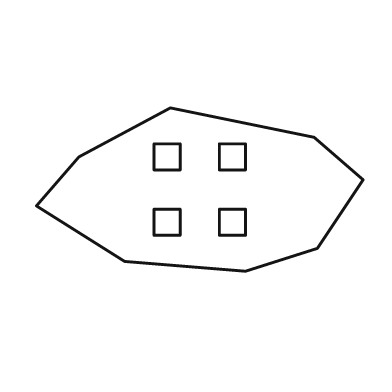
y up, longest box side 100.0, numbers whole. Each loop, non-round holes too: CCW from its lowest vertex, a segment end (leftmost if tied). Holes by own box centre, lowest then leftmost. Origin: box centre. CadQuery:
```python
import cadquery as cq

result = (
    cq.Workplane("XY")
    .moveTo(14.0, -25.0)
    .lineTo(36.0, -18.0)
    .lineTo(50.0, 3.0)
    .lineTo(35.0, 16.0)
    .lineTo(-9.0, 25.0)
    .lineTo(-37.0, 10.0)
    .lineTo(-50.0, -5.0)
    .lineTo(-23.0, -22.0)
    .close()
    .moveTo(-14.0, -14.0)
    .lineTo(-6.0, -14.0)
    .lineTo(-6.0, -6.0)
    .lineTo(-14.0, -6.0)
    .close()
    .moveTo(6.0, -14.0)
    .lineTo(14.0, -14.0)
    .lineTo(14.0, -6.0)
    .lineTo(6.0, -6.0)
    .close()
    .moveTo(-14.0, 6.0)
    .lineTo(-6.0, 6.0)
    .lineTo(-6.0, 14.0)
    .lineTo(-14.0, 14.0)
    .close()
    .moveTo(6.0, 6.0)
    .lineTo(14.0, 6.0)
    .lineTo(14.0, 14.0)
    .lineTo(6.0, 14.0)
    .close()
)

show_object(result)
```